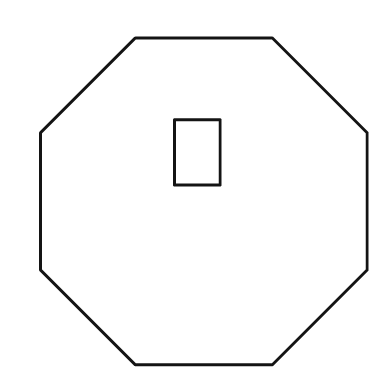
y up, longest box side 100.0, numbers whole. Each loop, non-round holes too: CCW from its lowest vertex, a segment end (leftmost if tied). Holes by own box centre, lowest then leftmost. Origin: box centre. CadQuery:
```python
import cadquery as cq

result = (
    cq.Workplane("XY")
    .moveTo(-21.0, -50.0)
    .lineTo(21.0, -50.0)
    .lineTo(50.0, -21.0)
    .lineTo(50.0, 21.0)
    .lineTo(21.0, 50.0)
    .lineTo(-21.0, 50.0)
    .lineTo(-50.0, 21.0)
    .lineTo(-50.0, -21.0)
    .close()
    .moveTo(-9.0, 5.0)
    .lineTo(5.0, 5.0)
    .lineTo(5.0, 25.0)
    .lineTo(-9.0, 25.0)
    .close()
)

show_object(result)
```